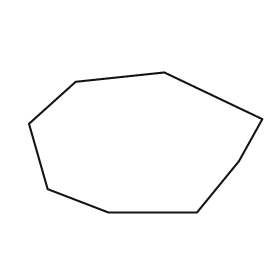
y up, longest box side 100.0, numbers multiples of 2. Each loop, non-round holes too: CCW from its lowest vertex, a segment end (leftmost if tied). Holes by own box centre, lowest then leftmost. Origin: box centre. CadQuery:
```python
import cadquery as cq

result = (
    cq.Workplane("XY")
    .moveTo(-16.0, -30.0)
    .lineTo(22.0, -30.0)
    .lineTo(40.0, -8.0)
    .lineTo(50.0, 10.0)
    .lineTo(8.0, 30.0)
    .lineTo(-30.0, 26.0)
    .lineTo(-50.0, 8.0)
    .lineTo(-42.0, -20.0)
    .close()
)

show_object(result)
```